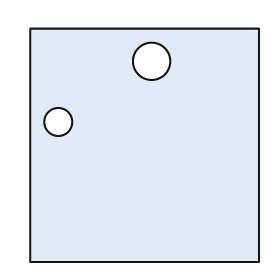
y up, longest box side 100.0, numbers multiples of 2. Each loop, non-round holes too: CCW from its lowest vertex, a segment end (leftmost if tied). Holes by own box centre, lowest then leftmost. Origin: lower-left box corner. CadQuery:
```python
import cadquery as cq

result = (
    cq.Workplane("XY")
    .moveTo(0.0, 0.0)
    .lineTo(98.0, 0.0)
    .lineTo(98.0, 100.0)
    .lineTo(0.0, 100.0)
    .close()
    .moveTo(12.0, 60.0)
    .circle(6.0)
    .moveTo(52.0, 86.0)
    .circle(8.0)
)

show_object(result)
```